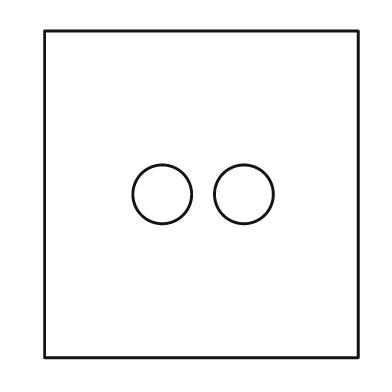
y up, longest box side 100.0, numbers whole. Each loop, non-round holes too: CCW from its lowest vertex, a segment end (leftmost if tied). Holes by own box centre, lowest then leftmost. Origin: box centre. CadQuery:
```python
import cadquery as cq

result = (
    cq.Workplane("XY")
    .moveTo(-48.0, -50.0)
    .lineTo(48.0, -50.0)
    .lineTo(48.0, 50.0)
    .lineTo(-48.0, 50.0)
    .close()
    .moveTo(-12.0, 0.0)
    .circle(9.0)
    .moveTo(13.0, 0.0)
    .circle(9.0)
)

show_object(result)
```